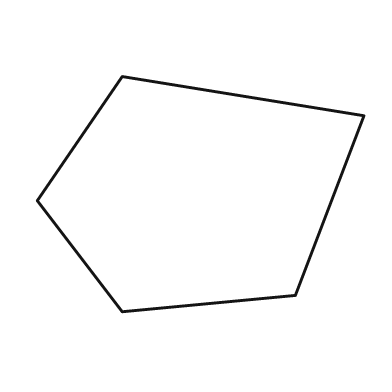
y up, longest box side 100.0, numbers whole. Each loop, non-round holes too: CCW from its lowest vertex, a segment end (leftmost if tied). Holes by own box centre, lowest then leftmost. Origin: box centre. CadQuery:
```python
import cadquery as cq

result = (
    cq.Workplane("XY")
    .moveTo(-24.0, -36.0)
    .lineTo(29.0, -31.0)
    .lineTo(50.0, 24.0)
    .lineTo(-24.0, 36.0)
    .lineTo(-50.0, -2.0)
    .close()
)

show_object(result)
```